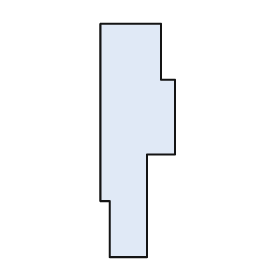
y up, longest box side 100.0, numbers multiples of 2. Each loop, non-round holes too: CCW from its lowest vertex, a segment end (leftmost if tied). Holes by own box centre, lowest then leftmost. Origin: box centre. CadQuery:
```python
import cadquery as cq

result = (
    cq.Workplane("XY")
    .moveTo(-12.0, -50.0)
    .lineTo(4.0, -50.0)
    .lineTo(4.0, -6.0)
    .lineTo(16.0, -6.0)
    .lineTo(16.0, 26.0)
    .lineTo(10.0, 26.0)
    .lineTo(10.0, 50.0)
    .lineTo(-16.0, 50.0)
    .lineTo(-16.0, -26.0)
    .lineTo(-12.0, -26.0)
    .close()
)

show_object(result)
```